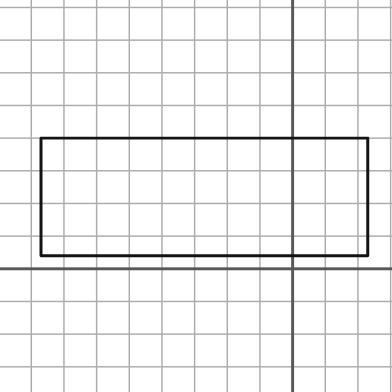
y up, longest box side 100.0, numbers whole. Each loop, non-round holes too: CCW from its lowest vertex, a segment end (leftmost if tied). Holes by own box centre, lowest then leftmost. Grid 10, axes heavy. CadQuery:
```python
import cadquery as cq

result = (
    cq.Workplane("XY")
    .moveTo(-77.0, 4.0)
    .lineTo(23.0, 4.0)
    .lineTo(23.0, 40.0)
    .lineTo(-77.0, 40.0)
    .close()
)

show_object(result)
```